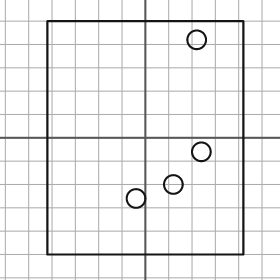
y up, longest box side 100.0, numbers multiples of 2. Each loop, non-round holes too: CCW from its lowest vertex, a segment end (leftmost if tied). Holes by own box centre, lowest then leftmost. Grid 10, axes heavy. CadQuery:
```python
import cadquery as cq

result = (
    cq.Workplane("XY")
    .moveTo(-42.0, -50.0)
    .lineTo(42.0, -50.0)
    .lineTo(42.0, 50.0)
    .lineTo(-42.0, 50.0)
    .close()
    .moveTo(-4.0, -26.0)
    .circle(4.0)
    .moveTo(12.0, -20.0)
    .circle(4.0)
    .moveTo(24.0, -6.0)
    .circle(4.0)
    .moveTo(22.0, 42.0)
    .circle(4.0)
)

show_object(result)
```